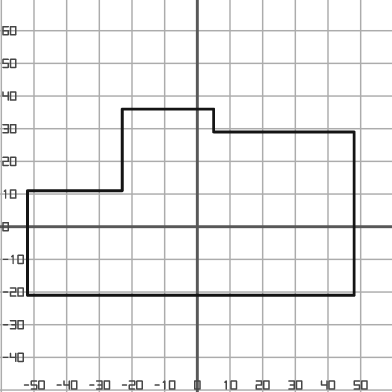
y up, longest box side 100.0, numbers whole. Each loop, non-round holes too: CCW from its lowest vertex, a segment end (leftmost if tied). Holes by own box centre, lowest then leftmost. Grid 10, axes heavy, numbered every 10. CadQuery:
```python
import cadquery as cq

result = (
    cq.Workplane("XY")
    .moveTo(-52.0, -21.0)
    .lineTo(48.0, -21.0)
    .lineTo(48.0, 29.0)
    .lineTo(5.0, 29.0)
    .lineTo(5.0, 36.0)
    .lineTo(-23.0, 36.0)
    .lineTo(-23.0, 11.0)
    .lineTo(-52.0, 11.0)
    .close()
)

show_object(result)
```